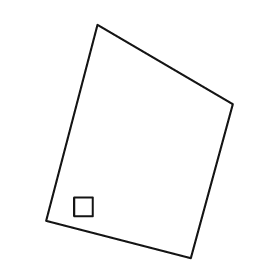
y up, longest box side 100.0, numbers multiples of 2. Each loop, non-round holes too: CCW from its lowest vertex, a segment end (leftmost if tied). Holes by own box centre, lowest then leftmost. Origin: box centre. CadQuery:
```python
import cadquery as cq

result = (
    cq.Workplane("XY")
    .moveTo(22.0, -50.0)
    .lineTo(40.0, 16.0)
    .lineTo(-18.0, 50.0)
    .lineTo(-40.0, -34.0)
    .close()
    .moveTo(-28.0, -32.0)
    .lineTo(-20.0, -32.0)
    .lineTo(-20.0, -24.0)
    .lineTo(-28.0, -24.0)
    .close()
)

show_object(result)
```